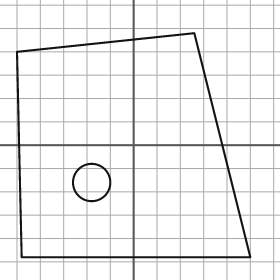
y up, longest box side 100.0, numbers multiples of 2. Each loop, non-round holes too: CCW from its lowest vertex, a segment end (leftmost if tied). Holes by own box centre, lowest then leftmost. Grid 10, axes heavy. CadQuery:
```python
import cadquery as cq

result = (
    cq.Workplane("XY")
    .moveTo(-48.0, -48.0)
    .lineTo(50.0, -48.0)
    .lineTo(26.0, 48.0)
    .lineTo(-50.0, 40.0)
    .close()
    .moveTo(-18.0, -16.0)
    .circle(8.0)
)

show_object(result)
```